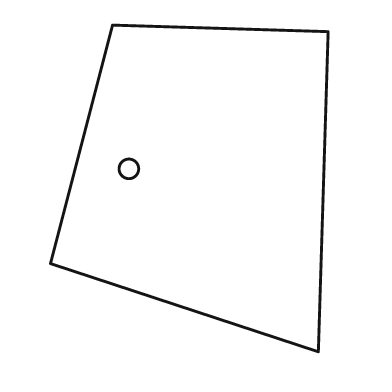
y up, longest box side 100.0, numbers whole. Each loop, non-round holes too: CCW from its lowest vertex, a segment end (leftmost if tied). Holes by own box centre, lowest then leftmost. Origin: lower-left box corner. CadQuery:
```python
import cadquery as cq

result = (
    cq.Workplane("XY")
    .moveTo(82.0, 0.0)
    .lineTo(85.0, 98.0)
    .lineTo(19.0, 100.0)
    .lineTo(0.0, 27.0)
    .close()
    .moveTo(24.0, 56.0)
    .circle(3.0)
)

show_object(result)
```